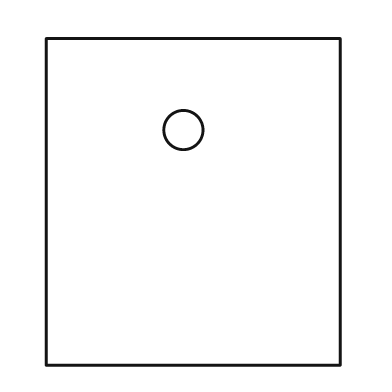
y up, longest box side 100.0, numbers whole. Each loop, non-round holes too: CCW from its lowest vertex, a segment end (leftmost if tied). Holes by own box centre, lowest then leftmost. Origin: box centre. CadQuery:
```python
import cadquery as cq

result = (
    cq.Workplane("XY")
    .moveTo(-45.0, -50.0)
    .lineTo(45.0, -50.0)
    .lineTo(45.0, 50.0)
    .lineTo(-45.0, 50.0)
    .close()
    .moveTo(-3.0, 22.0)
    .circle(6.0)
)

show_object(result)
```